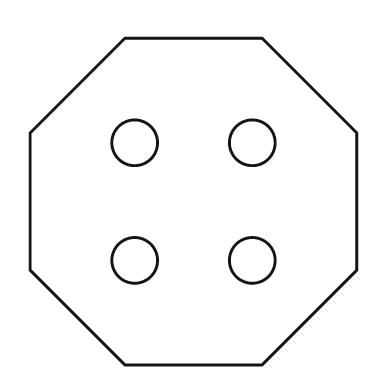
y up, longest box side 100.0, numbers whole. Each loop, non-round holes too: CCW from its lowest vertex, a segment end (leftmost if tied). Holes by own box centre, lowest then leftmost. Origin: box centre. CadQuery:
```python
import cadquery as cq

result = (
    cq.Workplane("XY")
    .moveTo(-21.0, -50.0)
    .lineTo(21.0, -50.0)
    .lineTo(50.0, -21.0)
    .lineTo(50.0, 21.0)
    .lineTo(21.0, 50.0)
    .lineTo(-21.0, 50.0)
    .lineTo(-50.0, 21.0)
    .lineTo(-50.0, -21.0)
    .close()
    .moveTo(-18.0, -18.0)
    .circle(7.0)
    .moveTo(18.0, -18.0)
    .circle(7.0)
    .moveTo(-18.0, 18.0)
    .circle(7.0)
    .moveTo(18.0, 18.0)
    .circle(7.0)
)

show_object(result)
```